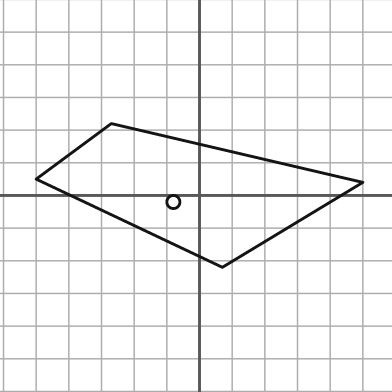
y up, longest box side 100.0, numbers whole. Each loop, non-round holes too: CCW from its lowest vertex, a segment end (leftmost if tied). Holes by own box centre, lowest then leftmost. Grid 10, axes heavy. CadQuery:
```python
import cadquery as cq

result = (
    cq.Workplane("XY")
    .moveTo(7.0, -22.0)
    .lineTo(50.0, 4.0)
    .lineTo(-27.0, 22.0)
    .lineTo(-50.0, 5.0)
    .close()
    .moveTo(-8.0, -2.0)
    .circle(2.0)
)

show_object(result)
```